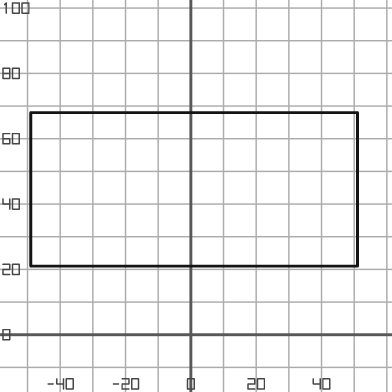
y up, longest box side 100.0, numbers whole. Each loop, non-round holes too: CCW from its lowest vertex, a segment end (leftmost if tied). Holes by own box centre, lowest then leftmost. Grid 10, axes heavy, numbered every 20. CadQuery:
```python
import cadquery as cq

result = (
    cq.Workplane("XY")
    .moveTo(-49.0, 21.0)
    .lineTo(51.0, 21.0)
    .lineTo(51.0, 68.0)
    .lineTo(-49.0, 68.0)
    .close()
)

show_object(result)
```